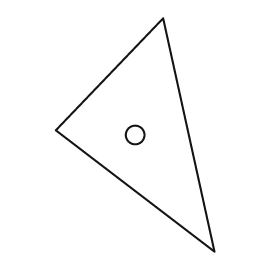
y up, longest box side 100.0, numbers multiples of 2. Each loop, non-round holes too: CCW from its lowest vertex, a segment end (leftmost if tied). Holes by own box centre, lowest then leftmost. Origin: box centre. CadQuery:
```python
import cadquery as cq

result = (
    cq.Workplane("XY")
    .moveTo(34.0, -50.0)
    .lineTo(12.0, 50.0)
    .lineTo(-34.0, 2.0)
    .close()
    .moveTo(0.0, 0.0)
    .circle(4.0)
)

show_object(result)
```